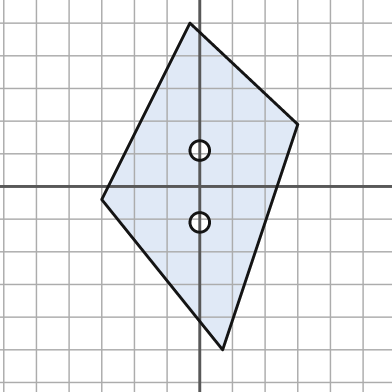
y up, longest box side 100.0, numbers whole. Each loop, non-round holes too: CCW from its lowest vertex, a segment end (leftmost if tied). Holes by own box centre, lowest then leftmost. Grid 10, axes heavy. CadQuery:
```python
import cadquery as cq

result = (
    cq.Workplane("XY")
    .moveTo(7.0, -50.0)
    .lineTo(30.0, 19.0)
    .lineTo(-3.0, 50.0)
    .lineTo(-30.0, -4.0)
    .close()
    .moveTo(0.0, -11.0)
    .circle(3.0)
    .moveTo(0.0, 11.0)
    .circle(3.0)
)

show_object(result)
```